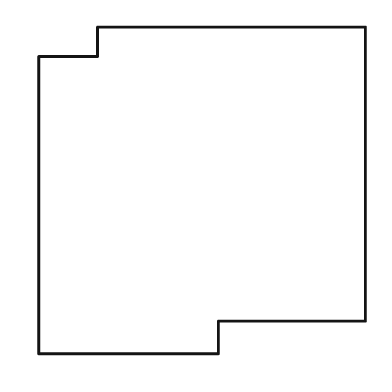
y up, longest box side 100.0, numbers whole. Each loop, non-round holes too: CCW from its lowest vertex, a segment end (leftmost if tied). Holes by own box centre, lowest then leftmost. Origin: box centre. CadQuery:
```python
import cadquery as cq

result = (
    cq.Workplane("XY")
    .moveTo(-50.0, -50.0)
    .lineTo(5.0, -50.0)
    .lineTo(5.0, -40.0)
    .lineTo(50.0, -40.0)
    .lineTo(50.0, 50.0)
    .lineTo(-32.0, 50.0)
    .lineTo(-32.0, 41.0)
    .lineTo(-50.0, 41.0)
    .close()
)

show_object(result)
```